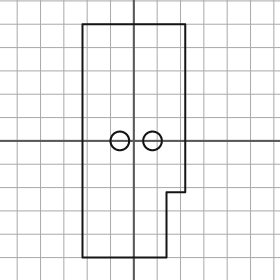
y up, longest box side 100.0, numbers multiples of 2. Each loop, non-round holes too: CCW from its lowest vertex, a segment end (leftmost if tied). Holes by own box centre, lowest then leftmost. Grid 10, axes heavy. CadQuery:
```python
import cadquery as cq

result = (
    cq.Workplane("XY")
    .moveTo(-22.0, -50.0)
    .lineTo(14.0, -50.0)
    .lineTo(14.0, -22.0)
    .lineTo(22.0, -22.0)
    .lineTo(22.0, 50.0)
    .lineTo(-22.0, 50.0)
    .close()
    .moveTo(-6.0, 0.0)
    .circle(4.0)
    .moveTo(8.0, 0.0)
    .circle(4.0)
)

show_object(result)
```